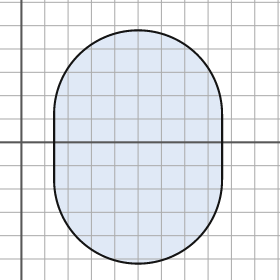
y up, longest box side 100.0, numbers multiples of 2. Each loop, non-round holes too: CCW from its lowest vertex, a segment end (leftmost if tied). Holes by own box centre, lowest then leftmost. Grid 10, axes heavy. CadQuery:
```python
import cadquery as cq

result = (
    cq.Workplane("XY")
    .moveTo(14.0, -16.0)
    .threePointArc((50.0, -52.0), (86.0, -16.0))
    .lineTo(86.0, 12.0)
    .threePointArc((50.0, 48.0), (14.0, 12.0))
    .close()
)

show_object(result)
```